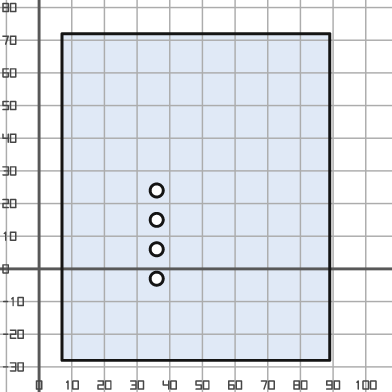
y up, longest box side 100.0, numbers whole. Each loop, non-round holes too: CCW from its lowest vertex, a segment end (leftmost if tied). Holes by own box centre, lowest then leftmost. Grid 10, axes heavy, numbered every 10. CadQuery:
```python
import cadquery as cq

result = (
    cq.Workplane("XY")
    .moveTo(7.0, -28.0)
    .lineTo(89.0, -28.0)
    .lineTo(89.0, 72.0)
    .lineTo(7.0, 72.0)
    .close()
    .moveTo(36.0, -3.0)
    .circle(2.0)
    .moveTo(36.0, 6.0)
    .circle(2.0)
    .moveTo(36.0, 15.0)
    .circle(2.0)
    .moveTo(36.0, 24.0)
    .circle(2.0)
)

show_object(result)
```